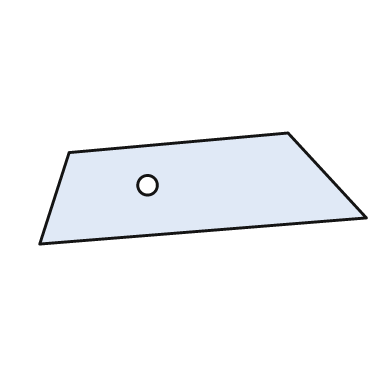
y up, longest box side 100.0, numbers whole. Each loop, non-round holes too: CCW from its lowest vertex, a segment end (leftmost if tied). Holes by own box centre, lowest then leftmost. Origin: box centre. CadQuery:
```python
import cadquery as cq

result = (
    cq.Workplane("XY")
    .moveTo(-50.0, -17.0)
    .lineTo(50.0, -9.0)
    .lineTo(26.0, 17.0)
    .lineTo(-41.0, 11.0)
    .close()
    .moveTo(-17.0, 1.0)
    .circle(3.0)
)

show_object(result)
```